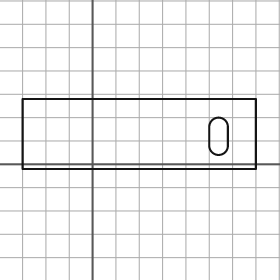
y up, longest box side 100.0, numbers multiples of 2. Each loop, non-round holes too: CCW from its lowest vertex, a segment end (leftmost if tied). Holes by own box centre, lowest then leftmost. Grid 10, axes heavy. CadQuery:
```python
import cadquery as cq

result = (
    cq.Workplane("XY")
    .moveTo(-30.0, -2.0)
    .lineTo(70.0, -2.0)
    .lineTo(70.0, 28.0)
    .lineTo(-30.0, 28.0)
    .close()
    .moveTo(50.0, 8.0)
    .threePointArc((54.0, 4.0), (58.0, 8.0))
    .lineTo(58.0, 16.0)
    .threePointArc((54.0, 20.0), (50.0, 16.0))
    .close()
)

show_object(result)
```